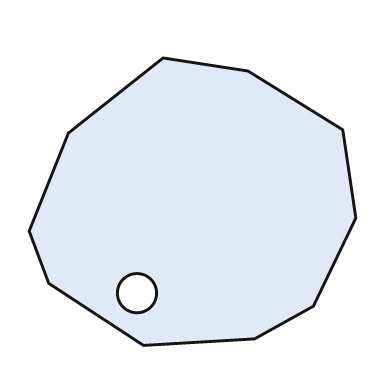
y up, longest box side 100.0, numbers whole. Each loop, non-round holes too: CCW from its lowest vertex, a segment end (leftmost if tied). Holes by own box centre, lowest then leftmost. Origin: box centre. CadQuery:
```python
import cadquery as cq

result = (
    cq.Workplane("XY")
    .moveTo(-15.0, -44.0)
    .lineTo(19.0, -42.0)
    .lineTo(37.0, -32.0)
    .lineTo(50.0, -5.0)
    .lineTo(46.0, 22.0)
    .lineTo(17.0, 40.0)
    .lineTo(-9.0, 44.0)
    .lineTo(-38.0, 21.0)
    .lineTo(-50.0, -9.0)
    .lineTo(-44.0, -25.0)
    .close()
    .moveTo(-17.0, -28.0)
    .circle(6.0)
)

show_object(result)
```